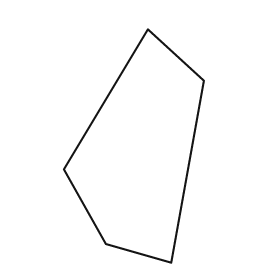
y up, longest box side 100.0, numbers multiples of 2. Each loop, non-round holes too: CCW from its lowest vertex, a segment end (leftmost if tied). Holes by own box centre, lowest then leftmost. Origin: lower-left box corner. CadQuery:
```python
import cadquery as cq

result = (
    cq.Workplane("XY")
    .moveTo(46.0, 0.0)
    .lineTo(60.0, 78.0)
    .lineTo(36.0, 100.0)
    .lineTo(0.0, 40.0)
    .lineTo(18.0, 8.0)
    .close()
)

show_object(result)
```